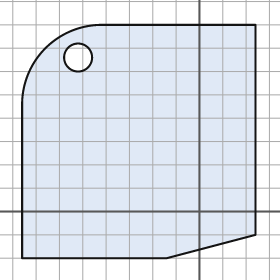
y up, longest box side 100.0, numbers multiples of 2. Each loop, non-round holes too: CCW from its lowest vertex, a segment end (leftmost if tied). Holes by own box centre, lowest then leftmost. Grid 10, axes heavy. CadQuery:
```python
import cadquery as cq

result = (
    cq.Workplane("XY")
    .moveTo(-76.0, -20.0)
    .lineTo(-14.0, -20.0)
    .lineTo(24.0, -10.0)
    .lineTo(24.0, 80.0)
    .lineTo(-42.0, 80.0)
    .threePointArc((-66.0, 70.0), (-76.0, 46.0))
    .close()
    .moveTo(-52.0, 66.0)
    .circle(6.0)
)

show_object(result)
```